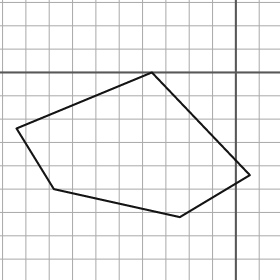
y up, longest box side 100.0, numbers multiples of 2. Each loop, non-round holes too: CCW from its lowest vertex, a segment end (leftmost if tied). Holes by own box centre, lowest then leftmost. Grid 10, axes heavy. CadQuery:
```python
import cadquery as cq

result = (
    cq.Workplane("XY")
    .moveTo(-24.0, -62.0)
    .lineTo(6.0, -44.0)
    .lineTo(-36.0, 0.0)
    .lineTo(-94.0, -24.0)
    .lineTo(-78.0, -50.0)
    .close()
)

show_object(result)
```